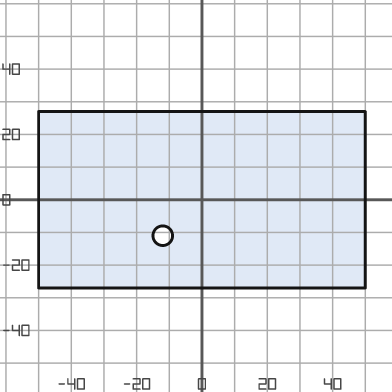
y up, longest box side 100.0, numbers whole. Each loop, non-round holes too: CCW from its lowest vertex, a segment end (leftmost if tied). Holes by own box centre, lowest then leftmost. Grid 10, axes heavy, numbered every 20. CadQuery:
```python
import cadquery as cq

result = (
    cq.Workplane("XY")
    .moveTo(-50.0, -27.0)
    .lineTo(50.0, -27.0)
    .lineTo(50.0, 27.0)
    .lineTo(-50.0, 27.0)
    .close()
    .moveTo(-12.0, -11.0)
    .circle(3.0)
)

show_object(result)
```